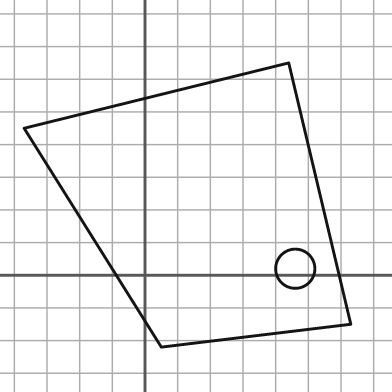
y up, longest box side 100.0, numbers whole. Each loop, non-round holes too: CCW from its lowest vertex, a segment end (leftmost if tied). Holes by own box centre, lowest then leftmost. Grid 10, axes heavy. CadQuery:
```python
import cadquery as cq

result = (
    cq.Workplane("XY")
    .moveTo(5.0, -22.0)
    .lineTo(63.0, -15.0)
    .lineTo(44.0, 65.0)
    .lineTo(-37.0, 45.0)
    .close()
    .moveTo(46.0, 2.0)
    .circle(6.0)
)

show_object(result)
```